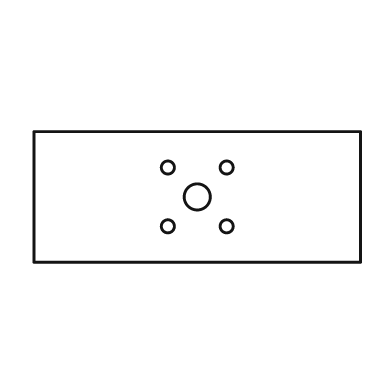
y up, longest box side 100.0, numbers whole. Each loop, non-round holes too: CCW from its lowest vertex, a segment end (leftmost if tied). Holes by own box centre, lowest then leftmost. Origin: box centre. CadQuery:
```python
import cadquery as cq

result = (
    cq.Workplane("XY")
    .moveTo(-50.0, -20.0)
    .lineTo(50.0, -20.0)
    .lineTo(50.0, 20.0)
    .lineTo(-50.0, 20.0)
    .close()
    .moveTo(-9.0, -9.0)
    .circle(2.0)
    .moveTo(9.0, -9.0)
    .circle(2.0)
    .moveTo(0.0, 0.0)
    .circle(4.0)
    .moveTo(-9.0, 9.0)
    .circle(2.0)
    .moveTo(9.0, 9.0)
    .circle(2.0)
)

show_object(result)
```